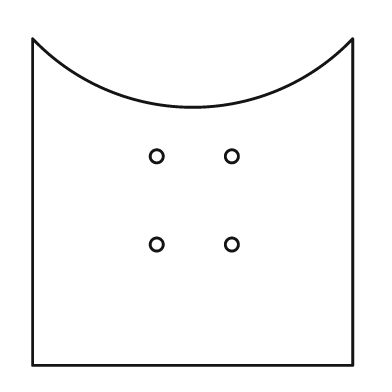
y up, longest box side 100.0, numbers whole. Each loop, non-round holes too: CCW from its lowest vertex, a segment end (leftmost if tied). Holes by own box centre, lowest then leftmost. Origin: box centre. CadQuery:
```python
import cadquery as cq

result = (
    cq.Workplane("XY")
    .moveTo(-49.0, -50.0)
    .lineTo(49.0, -50.0)
    .lineTo(49.0, 50.0)
    .threePointArc((0.0, 29.0), (-49.0, 50.0))
    .close()
    .moveTo(-11.0, -13.0)
    .circle(2.0)
    .moveTo(12.0, -13.0)
    .circle(2.0)
    .moveTo(-11.0, 14.0)
    .circle(2.0)
    .moveTo(12.0, 14.0)
    .circle(2.0)
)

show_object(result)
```